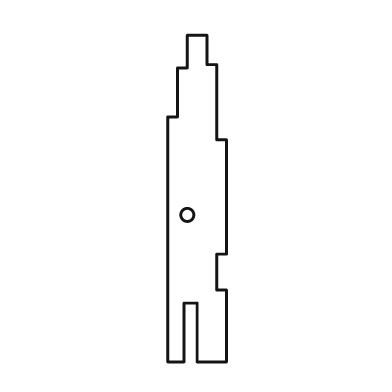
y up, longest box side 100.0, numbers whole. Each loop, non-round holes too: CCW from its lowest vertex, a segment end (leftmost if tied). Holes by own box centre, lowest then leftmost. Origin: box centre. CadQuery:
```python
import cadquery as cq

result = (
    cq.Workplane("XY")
    .moveTo(-9.0, -50.0)
    .lineTo(-4.0, -50.0)
    .lineTo(-4.0, -32.0)
    .lineTo(0.0, -32.0)
    .lineTo(0.0, -50.0)
    .lineTo(9.0, -50.0)
    .lineTo(9.0, -28.0)
    .lineTo(6.0, -28.0)
    .lineTo(6.0, -17.0)
    .lineTo(9.0, -17.0)
    .lineTo(9.0, 18.0)
    .lineTo(6.0, 18.0)
    .lineTo(6.0, 41.0)
    .lineTo(3.0, 41.0)
    .lineTo(3.0, 50.0)
    .lineTo(-3.0, 50.0)
    .lineTo(-3.0, 40.0)
    .lineTo(-6.0, 40.0)
    .lineTo(-6.0, 25.0)
    .lineTo(-9.0, 25.0)
    .close()
    .moveTo(-3.0, -5.0)
    .circle(2.0)
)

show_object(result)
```